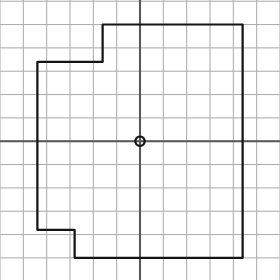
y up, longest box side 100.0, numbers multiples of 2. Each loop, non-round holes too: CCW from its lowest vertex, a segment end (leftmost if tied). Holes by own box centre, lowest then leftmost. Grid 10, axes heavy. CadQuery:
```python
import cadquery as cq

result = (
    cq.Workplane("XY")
    .moveTo(-28.0, -50.0)
    .lineTo(44.0, -50.0)
    .lineTo(44.0, 50.0)
    .lineTo(-16.0, 50.0)
    .lineTo(-16.0, 34.0)
    .lineTo(-44.0, 34.0)
    .lineTo(-44.0, -38.0)
    .lineTo(-28.0, -38.0)
    .close()
    .moveTo(0.0, 0.0)
    .circle(2.0)
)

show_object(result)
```